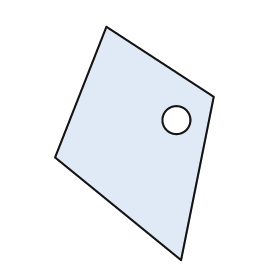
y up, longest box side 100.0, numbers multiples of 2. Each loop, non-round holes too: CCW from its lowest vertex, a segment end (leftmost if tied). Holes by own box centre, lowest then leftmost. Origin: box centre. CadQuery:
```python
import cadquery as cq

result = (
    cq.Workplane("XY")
    .moveTo(20.0, -50.0)
    .lineTo(34.0, 20.0)
    .lineTo(-12.0, 50.0)
    .lineTo(-34.0, -6.0)
    .close()
    .moveTo(18.0, 10.0)
    .circle(6.0)
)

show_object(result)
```